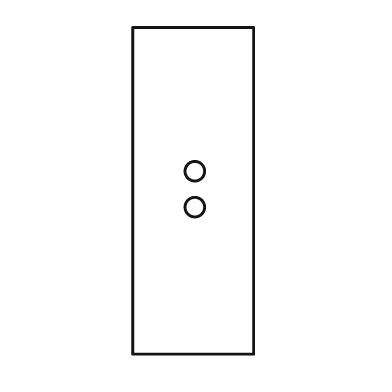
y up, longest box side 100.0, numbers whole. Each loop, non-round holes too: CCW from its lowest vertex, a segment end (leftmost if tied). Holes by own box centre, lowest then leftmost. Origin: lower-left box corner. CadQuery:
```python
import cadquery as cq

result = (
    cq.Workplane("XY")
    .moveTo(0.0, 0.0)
    .lineTo(37.0, 0.0)
    .lineTo(37.0, 100.0)
    .lineTo(0.0, 100.0)
    .close()
    .moveTo(19.0, 45.0)
    .circle(3.0)
    .moveTo(19.0, 56.0)
    .circle(3.0)
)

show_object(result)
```